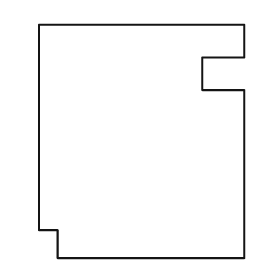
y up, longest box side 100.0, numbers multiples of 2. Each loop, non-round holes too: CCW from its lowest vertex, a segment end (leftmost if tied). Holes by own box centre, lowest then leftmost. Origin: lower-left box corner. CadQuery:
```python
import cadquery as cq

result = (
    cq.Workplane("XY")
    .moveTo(8.0, 0.0)
    .lineTo(88.0, 0.0)
    .lineTo(88.0, 72.0)
    .lineTo(70.0, 72.0)
    .lineTo(70.0, 86.0)
    .lineTo(88.0, 86.0)
    .lineTo(88.0, 100.0)
    .lineTo(0.0, 100.0)
    .lineTo(0.0, 12.0)
    .lineTo(8.0, 12.0)
    .close()
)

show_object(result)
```